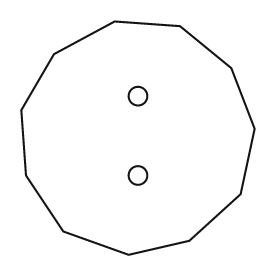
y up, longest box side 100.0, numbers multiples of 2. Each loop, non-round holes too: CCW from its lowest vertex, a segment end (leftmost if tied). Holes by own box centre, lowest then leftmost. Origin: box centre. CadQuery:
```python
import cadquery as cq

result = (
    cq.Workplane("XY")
    .moveTo(-4.0, -50.0)
    .lineTo(22.0, -44.0)
    .lineTo(44.0, -24.0)
    .lineTo(50.0, 4.0)
    .lineTo(40.0, 30.0)
    .lineTo(18.0, 48.0)
    .lineTo(-10.0, 50.0)
    .lineTo(-36.0, 36.0)
    .lineTo(-50.0, 12.0)
    .lineTo(-48.0, -16.0)
    .lineTo(-32.0, -40.0)
    .close()
    .moveTo(0.0, -16.0)
    .circle(4.0)
    .moveTo(0.0, 18.0)
    .circle(4.0)
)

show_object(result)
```